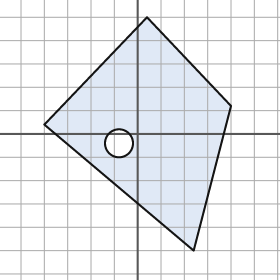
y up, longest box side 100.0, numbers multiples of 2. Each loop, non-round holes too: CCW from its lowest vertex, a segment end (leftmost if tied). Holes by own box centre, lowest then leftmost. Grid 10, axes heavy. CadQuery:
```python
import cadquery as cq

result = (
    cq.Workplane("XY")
    .moveTo(24.0, -50.0)
    .lineTo(40.0, 12.0)
    .lineTo(4.0, 50.0)
    .lineTo(-40.0, 4.0)
    .close()
    .moveTo(-8.0, -4.0)
    .circle(6.0)
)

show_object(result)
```